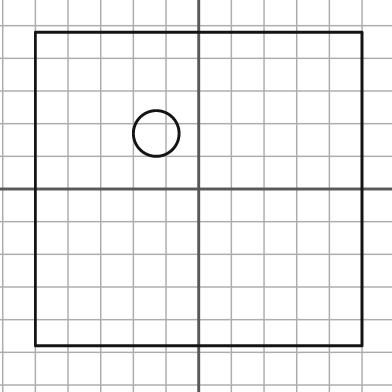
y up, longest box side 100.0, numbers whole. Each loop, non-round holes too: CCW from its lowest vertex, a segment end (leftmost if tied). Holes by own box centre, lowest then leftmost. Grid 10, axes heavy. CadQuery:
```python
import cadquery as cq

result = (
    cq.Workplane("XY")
    .moveTo(-50.0, -48.0)
    .lineTo(50.0, -48.0)
    .lineTo(50.0, 48.0)
    .lineTo(-50.0, 48.0)
    .close()
    .moveTo(-13.0, 17.0)
    .circle(7.0)
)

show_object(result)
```